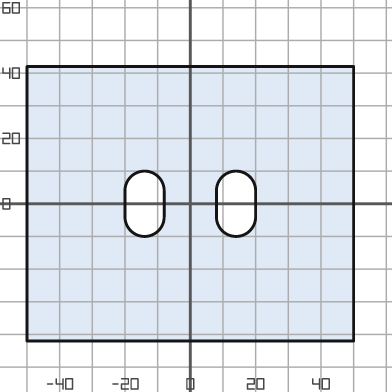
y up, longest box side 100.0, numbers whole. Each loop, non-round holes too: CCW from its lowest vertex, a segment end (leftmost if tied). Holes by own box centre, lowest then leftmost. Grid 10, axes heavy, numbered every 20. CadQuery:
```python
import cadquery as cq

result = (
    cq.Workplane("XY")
    .moveTo(-50.0, -42.0)
    .lineTo(50.0, -42.0)
    .lineTo(50.0, 42.0)
    .lineTo(-50.0, 42.0)
    .close()
    .moveTo(-20.0, -4.0)
    .threePointArc((-14.0, -10.0), (-8.0, -4.0))
    .lineTo(-8.0, 4.0)
    .threePointArc((-14.0, 10.0), (-20.0, 4.0))
    .close()
    .moveTo(8.0, -4.0)
    .threePointArc((14.0, -10.0), (20.0, -4.0))
    .lineTo(20.0, 4.0)
    .threePointArc((14.0, 10.0), (8.0, 4.0))
    .close()
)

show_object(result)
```